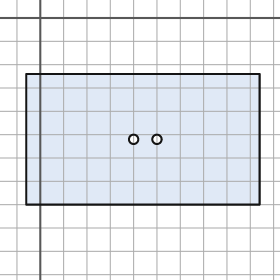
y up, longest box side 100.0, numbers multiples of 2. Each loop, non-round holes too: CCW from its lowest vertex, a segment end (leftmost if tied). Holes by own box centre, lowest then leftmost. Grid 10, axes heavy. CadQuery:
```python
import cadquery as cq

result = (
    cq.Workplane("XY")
    .moveTo(-6.0, -80.0)
    .lineTo(94.0, -80.0)
    .lineTo(94.0, -24.0)
    .lineTo(-6.0, -24.0)
    .close()
    .moveTo(40.0, -52.0)
    .circle(2.0)
    .moveTo(50.0, -52.0)
    .circle(2.0)
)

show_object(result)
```